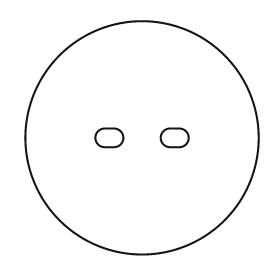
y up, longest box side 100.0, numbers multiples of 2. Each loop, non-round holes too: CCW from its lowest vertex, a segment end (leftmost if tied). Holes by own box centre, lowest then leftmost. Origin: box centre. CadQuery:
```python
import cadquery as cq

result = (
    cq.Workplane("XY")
    .moveTo(0.0, 0.0)
    .circle(50.0)
    .moveTo(-16.0, -4.0)
    .lineTo(-12.0, -4.0)
    .threePointArc((-8.0, 0.0), (-12.0, 4.0))
    .lineTo(-16.0, 4.0)
    .threePointArc((-20.0, 0.0), (-16.0, -4.0))
    .close()
    .moveTo(12.0, -4.0)
    .lineTo(16.0, -4.0)
    .threePointArc((20.0, 0.0), (16.0, 4.0))
    .lineTo(12.0, 4.0)
    .threePointArc((8.0, 0.0), (12.0, -4.0))
    .close()
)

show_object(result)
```